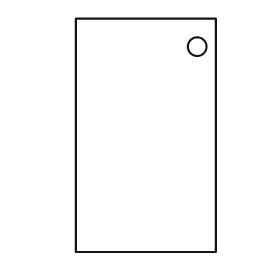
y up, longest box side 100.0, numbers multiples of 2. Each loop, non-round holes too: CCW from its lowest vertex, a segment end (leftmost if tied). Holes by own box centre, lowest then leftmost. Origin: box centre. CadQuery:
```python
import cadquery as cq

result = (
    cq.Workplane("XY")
    .moveTo(-30.0, -50.0)
    .lineTo(30.0, -50.0)
    .lineTo(30.0, 50.0)
    .lineTo(-30.0, 50.0)
    .close()
    .moveTo(22.0, 38.0)
    .circle(4.0)
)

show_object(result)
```